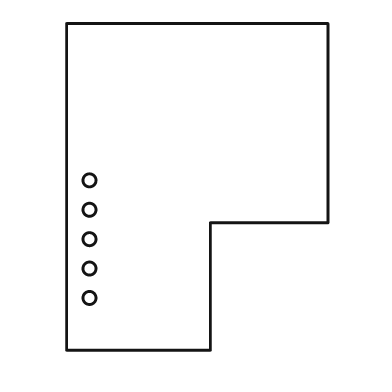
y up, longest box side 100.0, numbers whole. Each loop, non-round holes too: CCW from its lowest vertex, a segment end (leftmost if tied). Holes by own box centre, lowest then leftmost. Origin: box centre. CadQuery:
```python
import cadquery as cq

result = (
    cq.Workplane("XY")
    .moveTo(-40.0, -50.0)
    .lineTo(4.0, -50.0)
    .lineTo(4.0, -11.0)
    .lineTo(40.0, -11.0)
    .lineTo(40.0, 50.0)
    .lineTo(-40.0, 50.0)
    .close()
    .moveTo(-33.0, -34.0)
    .circle(2.0)
    .moveTo(-33.0, -25.0)
    .circle(2.0)
    .moveTo(-33.0, -16.0)
    .circle(2.0)
    .moveTo(-33.0, -7.0)
    .circle(2.0)
    .moveTo(-33.0, 2.0)
    .circle(2.0)
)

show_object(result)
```